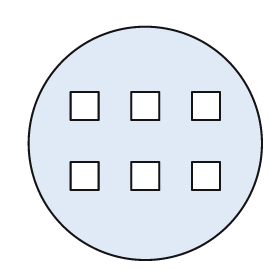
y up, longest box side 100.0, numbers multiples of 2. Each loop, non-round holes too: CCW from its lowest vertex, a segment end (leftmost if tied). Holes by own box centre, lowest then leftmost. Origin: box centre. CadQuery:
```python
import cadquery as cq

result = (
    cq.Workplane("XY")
    .moveTo(0.0, 0.0)
    .circle(50.0)
    .moveTo(-32.0, -20.0)
    .lineTo(-20.0, -20.0)
    .lineTo(-20.0, -8.0)
    .lineTo(-32.0, -8.0)
    .close()
    .moveTo(-6.0, -20.0)
    .lineTo(6.0, -20.0)
    .lineTo(6.0, -8.0)
    .lineTo(-6.0, -8.0)
    .close()
    .moveTo(20.0, -20.0)
    .lineTo(32.0, -20.0)
    .lineTo(32.0, -8.0)
    .lineTo(20.0, -8.0)
    .close()
    .moveTo(-32.0, 10.0)
    .lineTo(-20.0, 10.0)
    .lineTo(-20.0, 22.0)
    .lineTo(-32.0, 22.0)
    .close()
    .moveTo(-6.0, 10.0)
    .lineTo(6.0, 10.0)
    .lineTo(6.0, 22.0)
    .lineTo(-6.0, 22.0)
    .close()
    .moveTo(20.0, 10.0)
    .lineTo(32.0, 10.0)
    .lineTo(32.0, 22.0)
    .lineTo(20.0, 22.0)
    .close()
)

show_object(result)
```